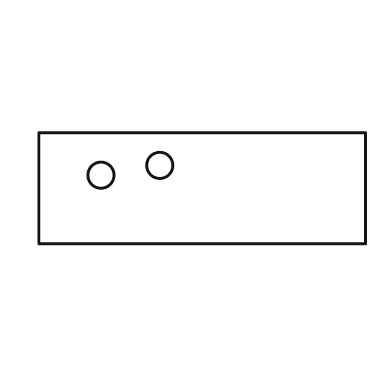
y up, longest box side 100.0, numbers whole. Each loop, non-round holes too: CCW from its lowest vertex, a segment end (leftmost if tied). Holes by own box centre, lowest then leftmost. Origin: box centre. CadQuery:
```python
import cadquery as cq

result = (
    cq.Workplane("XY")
    .moveTo(-50.0, -17.0)
    .lineTo(50.0, -17.0)
    .lineTo(50.0, 17.0)
    .lineTo(-50.0, 17.0)
    .close()
    .moveTo(-31.0, 4.0)
    .circle(4.0)
    .moveTo(-13.0, 7.0)
    .circle(4.0)
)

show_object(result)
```